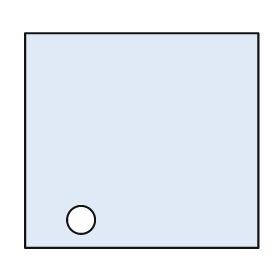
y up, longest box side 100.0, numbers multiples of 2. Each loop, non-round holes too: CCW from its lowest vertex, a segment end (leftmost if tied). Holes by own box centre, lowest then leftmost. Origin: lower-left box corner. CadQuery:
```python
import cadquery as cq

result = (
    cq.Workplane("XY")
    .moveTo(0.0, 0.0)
    .lineTo(100.0, 0.0)
    .lineTo(100.0, 92.0)
    .lineTo(0.0, 92.0)
    .close()
    .moveTo(24.0, 12.0)
    .circle(6.0)
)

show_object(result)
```